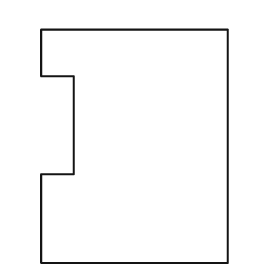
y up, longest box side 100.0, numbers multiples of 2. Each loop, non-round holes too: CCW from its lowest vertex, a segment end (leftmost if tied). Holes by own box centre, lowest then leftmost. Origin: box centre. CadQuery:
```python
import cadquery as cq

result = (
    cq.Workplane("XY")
    .moveTo(-40.0, -50.0)
    .lineTo(40.0, -50.0)
    .lineTo(40.0, 50.0)
    .lineTo(-40.0, 50.0)
    .lineTo(-40.0, 30.0)
    .lineTo(-26.0, 30.0)
    .lineTo(-26.0, -12.0)
    .lineTo(-40.0, -12.0)
    .close()
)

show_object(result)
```